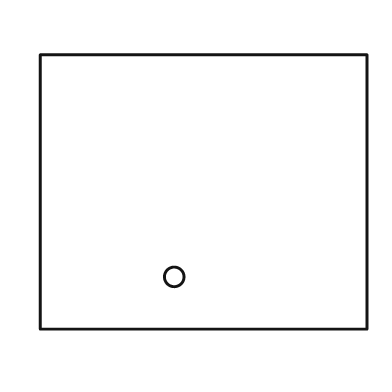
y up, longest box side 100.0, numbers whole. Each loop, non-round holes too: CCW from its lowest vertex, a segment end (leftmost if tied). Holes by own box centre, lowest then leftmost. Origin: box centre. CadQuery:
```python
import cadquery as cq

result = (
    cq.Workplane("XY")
    .moveTo(-50.0, -42.0)
    .lineTo(50.0, -42.0)
    .lineTo(50.0, 42.0)
    .lineTo(-50.0, 42.0)
    .close()
    .moveTo(-9.0, -26.0)
    .circle(3.0)
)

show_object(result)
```